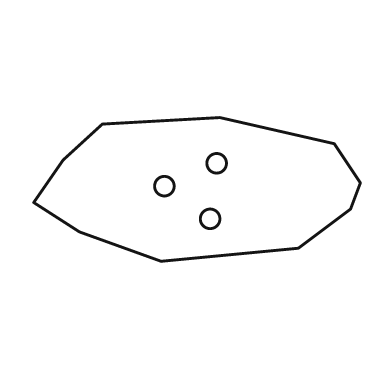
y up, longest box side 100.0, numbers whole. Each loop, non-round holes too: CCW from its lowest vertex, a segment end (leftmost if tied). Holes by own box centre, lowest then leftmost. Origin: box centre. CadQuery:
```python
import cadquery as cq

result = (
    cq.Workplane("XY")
    .moveTo(-11.0, -22.0)
    .lineTo(31.0, -18.0)
    .lineTo(47.0, -6.0)
    .lineTo(50.0, 2.0)
    .lineTo(42.0, 14.0)
    .lineTo(7.0, 22.0)
    .lineTo(-29.0, 20.0)
    .lineTo(-41.0, 9.0)
    .lineTo(-50.0, -4.0)
    .lineTo(-36.0, -13.0)
    .close()
    .moveTo(4.0, -9.0)
    .circle(3.0)
    .moveTo(-10.0, 1.0)
    .circle(3.0)
    .moveTo(6.0, 8.0)
    .circle(3.0)
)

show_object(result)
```